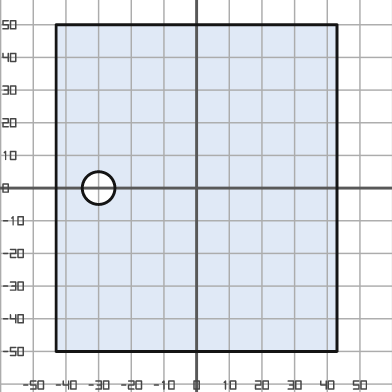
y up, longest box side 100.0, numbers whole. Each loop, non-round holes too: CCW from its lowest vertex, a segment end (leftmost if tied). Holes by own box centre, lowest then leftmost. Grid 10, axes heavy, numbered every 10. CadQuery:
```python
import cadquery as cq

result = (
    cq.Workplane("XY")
    .moveTo(-43.0, -50.0)
    .lineTo(43.0, -50.0)
    .lineTo(43.0, 50.0)
    .lineTo(-43.0, 50.0)
    .close()
    .moveTo(-30.0, 0.0)
    .circle(5.0)
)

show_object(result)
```